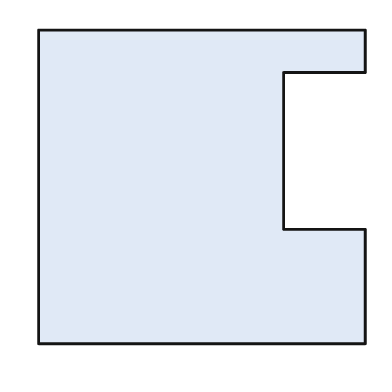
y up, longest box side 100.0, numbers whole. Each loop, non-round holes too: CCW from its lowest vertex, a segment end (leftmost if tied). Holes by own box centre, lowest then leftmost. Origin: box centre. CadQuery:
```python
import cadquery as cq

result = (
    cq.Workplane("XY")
    .moveTo(-50.0, -48.0)
    .lineTo(50.0, -48.0)
    .lineTo(50.0, -13.0)
    .lineTo(25.0, -13.0)
    .lineTo(25.0, 35.0)
    .lineTo(50.0, 35.0)
    .lineTo(50.0, 48.0)
    .lineTo(-50.0, 48.0)
    .close()
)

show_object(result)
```